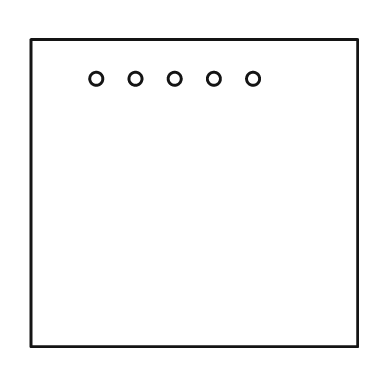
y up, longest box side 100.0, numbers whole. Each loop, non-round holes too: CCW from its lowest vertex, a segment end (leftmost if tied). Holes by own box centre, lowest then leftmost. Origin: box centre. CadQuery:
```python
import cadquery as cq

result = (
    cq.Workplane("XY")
    .moveTo(-50.0, -47.0)
    .lineTo(50.0, -47.0)
    .lineTo(50.0, 47.0)
    .lineTo(-50.0, 47.0)
    .close()
    .moveTo(-30.0, 35.0)
    .circle(2.0)
    .moveTo(-18.0, 35.0)
    .circle(2.0)
    .moveTo(-6.0, 35.0)
    .circle(2.0)
    .moveTo(6.0, 35.0)
    .circle(2.0)
    .moveTo(18.0, 35.0)
    .circle(2.0)
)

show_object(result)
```